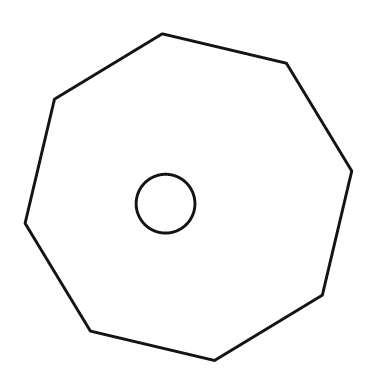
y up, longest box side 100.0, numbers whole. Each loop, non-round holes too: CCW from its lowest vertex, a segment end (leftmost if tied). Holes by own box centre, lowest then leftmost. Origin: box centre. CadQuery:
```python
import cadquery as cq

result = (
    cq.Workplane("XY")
    .moveTo(8.0, -50.0)
    .lineTo(41.0, -30.0)
    .lineTo(50.0, 8.0)
    .lineTo(30.0, 41.0)
    .lineTo(-8.0, 50.0)
    .lineTo(-41.0, 30.0)
    .lineTo(-50.0, -8.0)
    .lineTo(-30.0, -41.0)
    .close()
    .moveTo(-7.0, -2.0)
    .circle(9.0)
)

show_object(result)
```